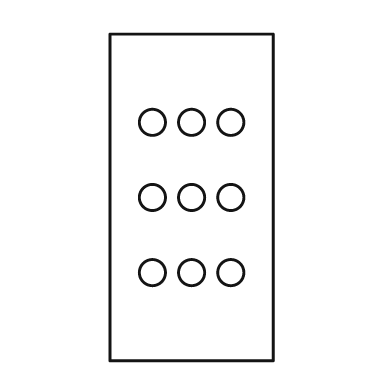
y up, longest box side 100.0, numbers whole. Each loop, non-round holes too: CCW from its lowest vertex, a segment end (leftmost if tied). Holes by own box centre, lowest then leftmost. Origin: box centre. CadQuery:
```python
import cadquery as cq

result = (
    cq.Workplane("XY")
    .moveTo(-25.0, -50.0)
    .lineTo(25.0, -50.0)
    .lineTo(25.0, 50.0)
    .lineTo(-25.0, 50.0)
    .close()
    .moveTo(-12.0, -23.0)
    .circle(4.0)
    .moveTo(0.0, -23.0)
    .circle(4.0)
    .moveTo(12.0, -23.0)
    .circle(4.0)
    .moveTo(-12.0, 0.0)
    .circle(4.0)
    .moveTo(0.0, 0.0)
    .circle(4.0)
    .moveTo(12.0, 0.0)
    .circle(4.0)
    .moveTo(-12.0, 23.0)
    .circle(4.0)
    .moveTo(0.0, 23.0)
    .circle(4.0)
    .moveTo(12.0, 23.0)
    .circle(4.0)
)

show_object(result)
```